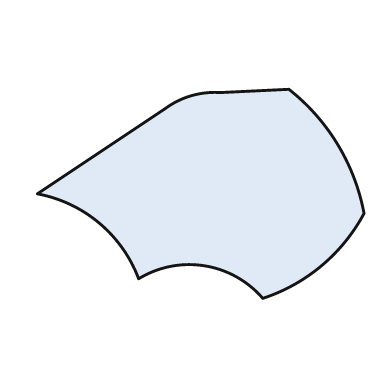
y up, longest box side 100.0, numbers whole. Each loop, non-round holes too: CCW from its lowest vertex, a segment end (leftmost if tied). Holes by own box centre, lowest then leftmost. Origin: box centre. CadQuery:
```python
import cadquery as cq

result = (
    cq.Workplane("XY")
    .moveTo(19.0, -32.0)
    .threePointArc((37.0, -22.0), (50.0, -6.0))
    .threePointArc((42.0, 15.0), (27.0, 32.0))
    .lineTo(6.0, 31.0)
    .threePointArc((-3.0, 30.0), (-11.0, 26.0))
    .lineTo(-50.0, 0.0)
    .threePointArc((-31.0, -9.0), (-19.0, -26.0))
    .threePointArc((1.0, -22.0), (19.0, -32.0))
    .close()
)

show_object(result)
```